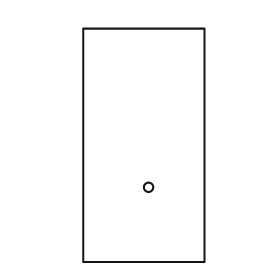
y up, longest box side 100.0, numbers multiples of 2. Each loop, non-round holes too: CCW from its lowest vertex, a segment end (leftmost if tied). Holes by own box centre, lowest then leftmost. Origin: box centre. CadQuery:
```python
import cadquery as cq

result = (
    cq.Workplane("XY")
    .moveTo(-26.0, -50.0)
    .lineTo(26.0, -50.0)
    .lineTo(26.0, 50.0)
    .lineTo(-26.0, 50.0)
    .close()
    .moveTo(2.0, -18.0)
    .circle(2.0)
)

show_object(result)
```